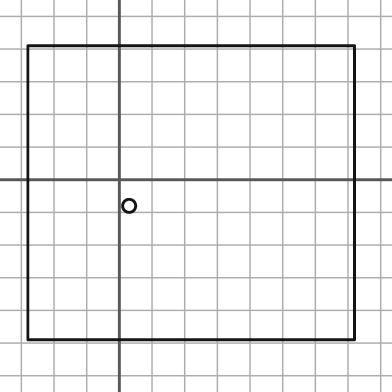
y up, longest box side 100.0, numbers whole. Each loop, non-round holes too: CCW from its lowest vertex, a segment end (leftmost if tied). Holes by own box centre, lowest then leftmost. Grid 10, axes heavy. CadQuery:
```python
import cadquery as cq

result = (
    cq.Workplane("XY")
    .moveTo(-28.0, -49.0)
    .lineTo(72.0, -49.0)
    .lineTo(72.0, 41.0)
    .lineTo(-28.0, 41.0)
    .close()
    .moveTo(3.0, -8.0)
    .circle(2.0)
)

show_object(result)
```